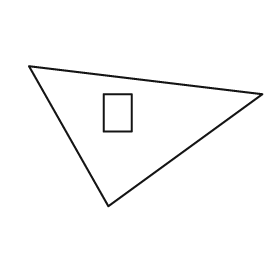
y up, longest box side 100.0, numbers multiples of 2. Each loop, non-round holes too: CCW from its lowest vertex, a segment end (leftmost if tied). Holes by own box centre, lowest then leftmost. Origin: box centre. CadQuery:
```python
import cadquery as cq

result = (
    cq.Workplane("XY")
    .moveTo(-16.0, -30.0)
    .lineTo(50.0, 18.0)
    .lineTo(-50.0, 30.0)
    .close()
    .moveTo(-18.0, 2.0)
    .lineTo(-6.0, 2.0)
    .lineTo(-6.0, 18.0)
    .lineTo(-18.0, 18.0)
    .close()
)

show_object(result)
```